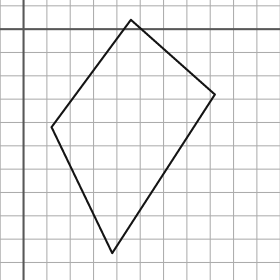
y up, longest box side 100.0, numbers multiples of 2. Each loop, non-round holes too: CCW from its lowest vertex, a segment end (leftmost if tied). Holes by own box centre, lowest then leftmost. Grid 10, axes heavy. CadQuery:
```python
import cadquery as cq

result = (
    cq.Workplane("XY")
    .moveTo(38.0, -96.0)
    .lineTo(82.0, -28.0)
    .lineTo(46.0, 4.0)
    .lineTo(12.0, -42.0)
    .close()
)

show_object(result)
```